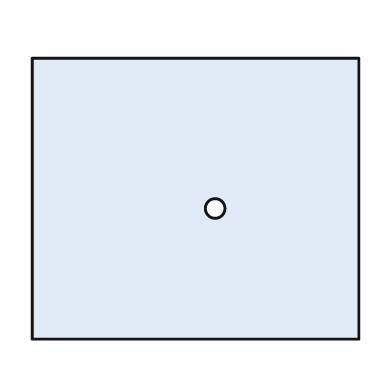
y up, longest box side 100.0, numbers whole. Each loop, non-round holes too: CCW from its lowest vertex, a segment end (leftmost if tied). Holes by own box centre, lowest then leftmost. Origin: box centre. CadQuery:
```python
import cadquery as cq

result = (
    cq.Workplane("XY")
    .moveTo(-50.0, -43.0)
    .lineTo(50.0, -43.0)
    .lineTo(50.0, 43.0)
    .lineTo(-50.0, 43.0)
    .close()
    .moveTo(6.0, -3.0)
    .circle(3.0)
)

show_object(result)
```